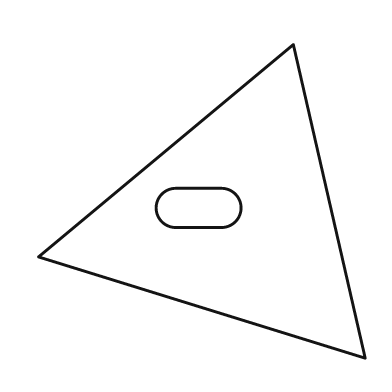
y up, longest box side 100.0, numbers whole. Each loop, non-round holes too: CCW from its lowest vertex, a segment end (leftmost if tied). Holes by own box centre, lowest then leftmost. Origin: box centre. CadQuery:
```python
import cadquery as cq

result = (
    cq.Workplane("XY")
    .moveTo(50.0, -48.0)
    .lineTo(28.0, 48.0)
    .lineTo(-50.0, -17.0)
    .close()
    .moveTo(-8.0, -8.0)
    .lineTo(6.0, -8.0)
    .threePointArc((12.0, -2.0), (6.0, 4.0))
    .lineTo(-8.0, 4.0)
    .threePointArc((-14.0, -2.0), (-8.0, -8.0))
    .close()
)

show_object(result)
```